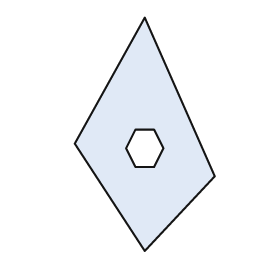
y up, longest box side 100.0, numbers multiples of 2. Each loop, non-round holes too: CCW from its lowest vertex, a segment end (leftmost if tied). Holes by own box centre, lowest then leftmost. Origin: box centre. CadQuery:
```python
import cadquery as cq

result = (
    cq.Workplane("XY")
    .moveTo(0.0, -50.0)
    .lineTo(30.0, -18.0)
    .lineTo(0.0, 50.0)
    .lineTo(-30.0, -4.0)
    .close()
    .moveTo(-4.0, -14.0)
    .lineTo(4.0, -14.0)
    .lineTo(8.0, -6.0)
    .lineTo(4.0, 2.0)
    .lineTo(-4.0, 2.0)
    .lineTo(-8.0, -6.0)
    .close()
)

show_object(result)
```